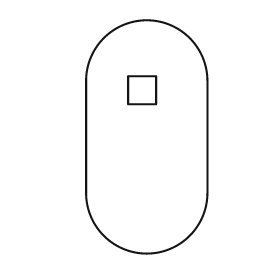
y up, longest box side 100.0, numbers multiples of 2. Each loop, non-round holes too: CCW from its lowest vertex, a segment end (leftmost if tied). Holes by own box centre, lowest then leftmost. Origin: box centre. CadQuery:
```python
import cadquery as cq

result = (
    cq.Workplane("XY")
    .moveTo(-26.0, -24.0)
    .threePointArc((0.0, -50.0), (26.0, -24.0))
    .lineTo(26.0, 24.0)
    .threePointArc((0.0, 50.0), (-26.0, 24.0))
    .close()
    .moveTo(-8.0, 14.0)
    .lineTo(4.0, 14.0)
    .lineTo(4.0, 26.0)
    .lineTo(-8.0, 26.0)
    .close()
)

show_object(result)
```